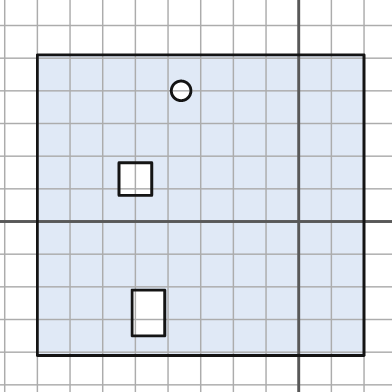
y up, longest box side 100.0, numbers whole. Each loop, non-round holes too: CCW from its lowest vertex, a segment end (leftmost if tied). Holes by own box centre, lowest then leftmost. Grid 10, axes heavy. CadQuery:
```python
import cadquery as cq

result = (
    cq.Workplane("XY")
    .moveTo(-80.0, -41.0)
    .lineTo(20.0, -41.0)
    .lineTo(20.0, 51.0)
    .lineTo(-80.0, 51.0)
    .close()
    .moveTo(-51.0, -35.0)
    .lineTo(-41.0, -35.0)
    .lineTo(-41.0, -21.0)
    .lineTo(-51.0, -21.0)
    .close()
    .moveTo(-55.0, 8.0)
    .lineTo(-45.0, 8.0)
    .lineTo(-45.0, 18.0)
    .lineTo(-55.0, 18.0)
    .close()
    .moveTo(-36.0, 40.0)
    .circle(3.0)
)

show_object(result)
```